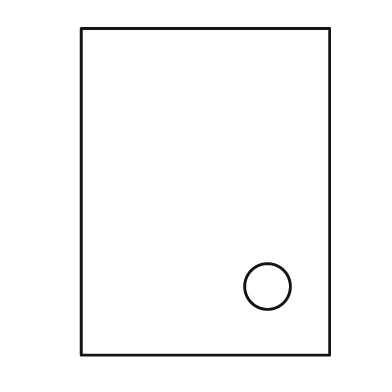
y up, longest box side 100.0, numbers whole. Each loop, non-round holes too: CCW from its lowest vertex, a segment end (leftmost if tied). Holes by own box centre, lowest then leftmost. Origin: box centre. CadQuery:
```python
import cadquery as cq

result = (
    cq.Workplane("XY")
    .moveTo(-38.0, -50.0)
    .lineTo(38.0, -50.0)
    .lineTo(38.0, 50.0)
    .lineTo(-38.0, 50.0)
    .close()
    .moveTo(19.0, -29.0)
    .circle(7.0)
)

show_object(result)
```